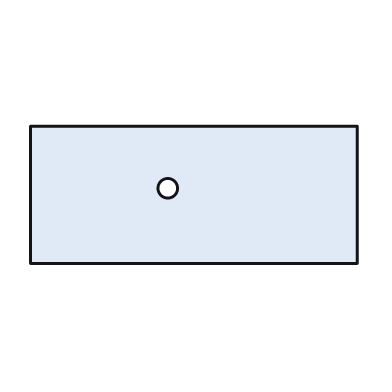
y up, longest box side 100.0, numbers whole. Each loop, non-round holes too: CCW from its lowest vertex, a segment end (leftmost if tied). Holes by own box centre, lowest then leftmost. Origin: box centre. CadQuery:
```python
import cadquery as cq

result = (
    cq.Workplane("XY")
    .moveTo(-50.0, -21.0)
    .lineTo(50.0, -21.0)
    .lineTo(50.0, 21.0)
    .lineTo(-50.0, 21.0)
    .close()
    .moveTo(-8.0, 2.0)
    .circle(3.0)
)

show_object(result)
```